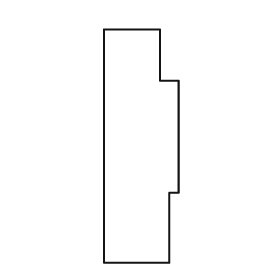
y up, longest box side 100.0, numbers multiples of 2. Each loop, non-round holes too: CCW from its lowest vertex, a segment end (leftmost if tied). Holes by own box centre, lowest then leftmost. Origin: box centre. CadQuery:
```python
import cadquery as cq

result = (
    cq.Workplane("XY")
    .moveTo(-16.0, -50.0)
    .lineTo(12.0, -50.0)
    .lineTo(12.0, -20.0)
    .lineTo(16.0, -20.0)
    .lineTo(16.0, 28.0)
    .lineTo(8.0, 28.0)
    .lineTo(8.0, 50.0)
    .lineTo(-16.0, 50.0)
    .close()
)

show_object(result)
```